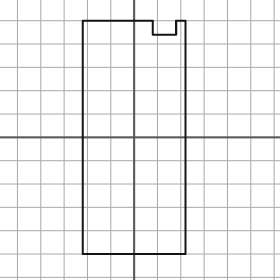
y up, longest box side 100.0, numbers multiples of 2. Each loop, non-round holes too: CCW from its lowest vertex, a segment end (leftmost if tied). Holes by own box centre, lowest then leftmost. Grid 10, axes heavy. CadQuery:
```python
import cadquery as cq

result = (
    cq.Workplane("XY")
    .moveTo(-22.0, -50.0)
    .lineTo(22.0, -50.0)
    .lineTo(22.0, 50.0)
    .lineTo(18.0, 50.0)
    .lineTo(18.0, 44.0)
    .lineTo(8.0, 44.0)
    .lineTo(8.0, 50.0)
    .lineTo(-22.0, 50.0)
    .close()
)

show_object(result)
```